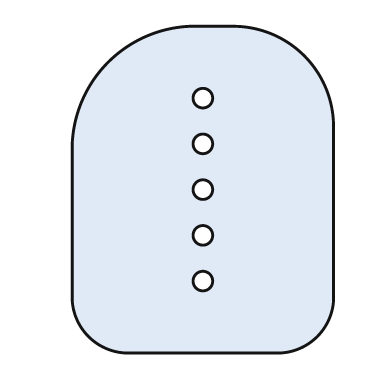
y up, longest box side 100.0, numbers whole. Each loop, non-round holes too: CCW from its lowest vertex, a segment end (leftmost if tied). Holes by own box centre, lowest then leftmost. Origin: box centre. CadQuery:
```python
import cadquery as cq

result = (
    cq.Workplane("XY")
    .moveTo(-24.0, -50.0)
    .lineTo(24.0, -50.0)
    .threePointArc((35.0, -45.0), (40.0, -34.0))
    .lineTo(40.0, 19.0)
    .threePointArc((31.0, 41.0), (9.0, 50.0))
    .lineTo(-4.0, 50.0)
    .threePointArc((-29.0, 39.0), (-40.0, 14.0))
    .lineTo(-40.0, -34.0)
    .threePointArc((-35.0, -45.0), (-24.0, -50.0))
    .close()
    .moveTo(0.0, -28.0)
    .circle(3.0)
    .moveTo(0.0, -14.0)
    .circle(3.0)
    .moveTo(0.0, 0.0)
    .circle(3.0)
    .moveTo(0.0, 14.0)
    .circle(3.0)
    .moveTo(0.0, 28.0)
    .circle(3.0)
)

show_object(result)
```